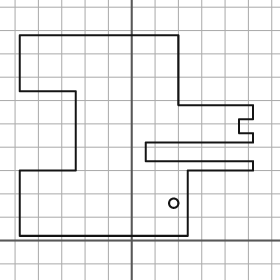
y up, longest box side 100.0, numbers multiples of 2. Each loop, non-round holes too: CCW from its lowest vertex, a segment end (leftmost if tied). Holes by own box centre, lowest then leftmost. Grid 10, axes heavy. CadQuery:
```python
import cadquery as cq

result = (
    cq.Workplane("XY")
    .moveTo(-48.0, 2.0)
    .lineTo(24.0, 2.0)
    .lineTo(24.0, 30.0)
    .lineTo(52.0, 30.0)
    .lineTo(52.0, 34.0)
    .lineTo(6.0, 34.0)
    .lineTo(6.0, 42.0)
    .lineTo(52.0, 42.0)
    .lineTo(52.0, 46.0)
    .lineTo(46.0, 46.0)
    .lineTo(46.0, 52.0)
    .lineTo(52.0, 52.0)
    .lineTo(52.0, 58.0)
    .lineTo(20.0, 58.0)
    .lineTo(20.0, 88.0)
    .lineTo(-48.0, 88.0)
    .lineTo(-48.0, 64.0)
    .lineTo(-24.0, 64.0)
    .lineTo(-24.0, 30.0)
    .lineTo(-48.0, 30.0)
    .close()
    .moveTo(18.0, 16.0)
    .circle(2.0)
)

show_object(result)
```